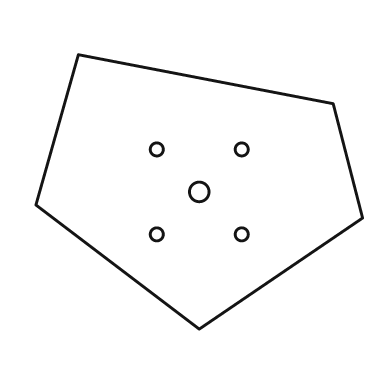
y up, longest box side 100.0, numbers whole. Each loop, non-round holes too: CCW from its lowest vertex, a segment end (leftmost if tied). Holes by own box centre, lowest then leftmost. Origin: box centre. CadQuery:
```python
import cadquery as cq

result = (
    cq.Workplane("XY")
    .moveTo(0.0, -42.0)
    .lineTo(50.0, -8.0)
    .lineTo(41.0, 27.0)
    .lineTo(-37.0, 42.0)
    .lineTo(-50.0, -4.0)
    .close()
    .moveTo(-13.0, -13.0)
    .circle(2.0)
    .moveTo(13.0, -13.0)
    .circle(2.0)
    .moveTo(0.0, 0.0)
    .circle(3.0)
    .moveTo(-13.0, 13.0)
    .circle(2.0)
    .moveTo(13.0, 13.0)
    .circle(2.0)
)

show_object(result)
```